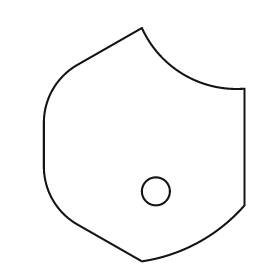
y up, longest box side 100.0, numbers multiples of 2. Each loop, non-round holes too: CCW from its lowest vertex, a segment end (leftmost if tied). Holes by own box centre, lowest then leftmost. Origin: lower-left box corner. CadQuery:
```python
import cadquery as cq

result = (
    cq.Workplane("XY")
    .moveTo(42.0, 0.0)
    .threePointArc((66.0, 8.0), (86.0, 24.0))
    .lineTo(86.0, 74.0)
    .threePointArc((60.0, 80.0), (42.0, 100.0))
    .lineTo(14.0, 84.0)
    .threePointArc((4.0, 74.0), (0.0, 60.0))
    .lineTo(0.0, 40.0)
    .threePointArc((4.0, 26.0), (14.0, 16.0))
    .close()
    .moveTo(48.0, 30.0)
    .circle(6.0)
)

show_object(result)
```